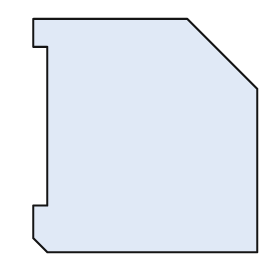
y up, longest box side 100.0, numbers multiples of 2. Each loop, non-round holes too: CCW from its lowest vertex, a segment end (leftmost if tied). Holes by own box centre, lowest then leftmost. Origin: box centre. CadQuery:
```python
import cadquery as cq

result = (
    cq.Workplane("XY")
    .moveTo(-42.0, -50.0)
    .lineTo(48.0, -50.0)
    .lineTo(48.0, 20.0)
    .lineTo(18.0, 50.0)
    .lineTo(-48.0, 50.0)
    .lineTo(-48.0, 38.0)
    .lineTo(-42.0, 38.0)
    .lineTo(-42.0, -30.0)
    .lineTo(-48.0, -30.0)
    .lineTo(-48.0, -44.0)
    .close()
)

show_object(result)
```